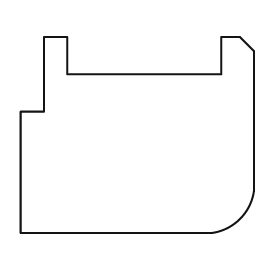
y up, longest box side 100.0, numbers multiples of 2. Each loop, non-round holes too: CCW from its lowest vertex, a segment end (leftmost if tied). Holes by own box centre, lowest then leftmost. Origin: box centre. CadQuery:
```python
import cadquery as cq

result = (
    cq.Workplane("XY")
    .moveTo(-50.0, -42.0)
    .lineTo(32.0, -42.0)
    .threePointArc((44.0, -36.0), (50.0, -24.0))
    .lineTo(50.0, 36.0)
    .lineTo(44.0, 42.0)
    .lineTo(36.0, 42.0)
    .lineTo(36.0, 26.0)
    .lineTo(-30.0, 26.0)
    .lineTo(-30.0, 42.0)
    .lineTo(-40.0, 42.0)
    .lineTo(-40.0, 10.0)
    .lineTo(-50.0, 10.0)
    .close()
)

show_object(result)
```